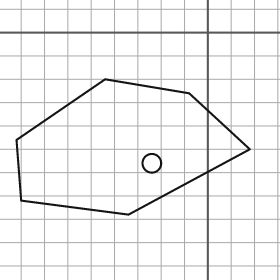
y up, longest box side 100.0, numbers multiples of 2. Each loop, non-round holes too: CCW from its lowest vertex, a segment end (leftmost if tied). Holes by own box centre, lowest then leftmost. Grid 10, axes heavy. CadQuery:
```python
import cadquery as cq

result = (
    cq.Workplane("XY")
    .moveTo(-34.0, -78.0)
    .lineTo(18.0, -50.0)
    .lineTo(-8.0, -26.0)
    .lineTo(-44.0, -20.0)
    .lineTo(-82.0, -46.0)
    .lineTo(-80.0, -72.0)
    .close()
    .moveTo(-24.0, -56.0)
    .circle(4.0)
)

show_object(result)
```